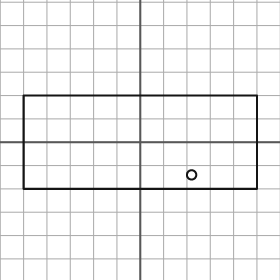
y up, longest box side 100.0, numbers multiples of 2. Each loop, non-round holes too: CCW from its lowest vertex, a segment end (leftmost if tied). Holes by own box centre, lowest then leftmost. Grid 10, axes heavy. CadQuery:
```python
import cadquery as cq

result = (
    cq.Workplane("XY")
    .moveTo(-50.0, -20.0)
    .lineTo(50.0, -20.0)
    .lineTo(50.0, 20.0)
    .lineTo(-50.0, 20.0)
    .close()
    .moveTo(22.0, -14.0)
    .circle(2.0)
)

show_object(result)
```